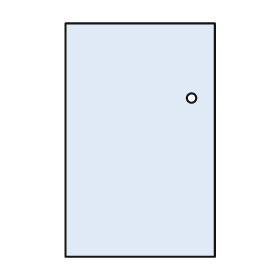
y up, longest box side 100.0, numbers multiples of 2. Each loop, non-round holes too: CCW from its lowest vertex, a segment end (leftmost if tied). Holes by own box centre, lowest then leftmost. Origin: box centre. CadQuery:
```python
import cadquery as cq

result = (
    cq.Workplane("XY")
    .moveTo(-32.0, -50.0)
    .lineTo(32.0, -50.0)
    .lineTo(32.0, 50.0)
    .lineTo(-32.0, 50.0)
    .close()
    .moveTo(22.0, 18.0)
    .circle(2.0)
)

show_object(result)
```